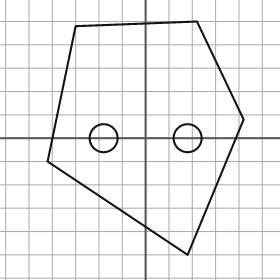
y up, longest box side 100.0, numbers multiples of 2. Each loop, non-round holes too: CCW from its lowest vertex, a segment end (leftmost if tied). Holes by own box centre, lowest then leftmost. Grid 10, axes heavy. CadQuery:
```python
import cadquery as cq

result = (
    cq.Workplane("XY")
    .moveTo(18.0, -50.0)
    .lineTo(42.0, 8.0)
    .lineTo(22.0, 50.0)
    .lineTo(-30.0, 48.0)
    .lineTo(-42.0, -10.0)
    .close()
    .moveTo(-18.0, 0.0)
    .circle(6.0)
    .moveTo(18.0, 0.0)
    .circle(6.0)
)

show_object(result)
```